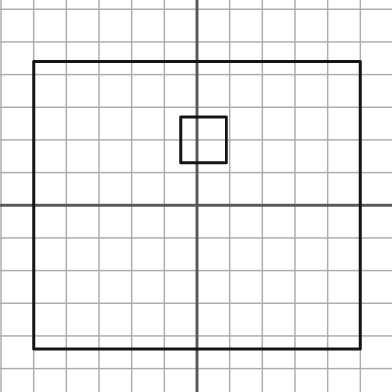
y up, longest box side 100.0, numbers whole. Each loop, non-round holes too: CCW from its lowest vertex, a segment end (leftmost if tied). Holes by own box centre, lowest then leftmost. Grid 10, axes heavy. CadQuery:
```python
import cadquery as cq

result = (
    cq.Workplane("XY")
    .moveTo(-50.0, -44.0)
    .lineTo(50.0, -44.0)
    .lineTo(50.0, 44.0)
    .lineTo(-50.0, 44.0)
    .close()
    .moveTo(-5.0, 13.0)
    .lineTo(9.0, 13.0)
    .lineTo(9.0, 27.0)
    .lineTo(-5.0, 27.0)
    .close()
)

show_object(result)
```